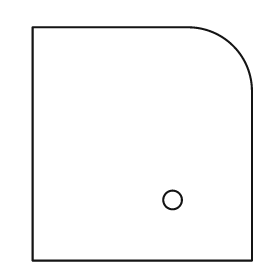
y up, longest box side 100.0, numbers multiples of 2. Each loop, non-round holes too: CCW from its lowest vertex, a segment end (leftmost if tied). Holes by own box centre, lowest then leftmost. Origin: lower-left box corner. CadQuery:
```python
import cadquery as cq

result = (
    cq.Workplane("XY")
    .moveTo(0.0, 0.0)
    .lineTo(94.0, 0.0)
    .lineTo(94.0, 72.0)
    .threePointArc((86.0, 92.0), (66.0, 100.0))
    .lineTo(0.0, 100.0)
    .close()
    .moveTo(60.0, 26.0)
    .circle(4.0)
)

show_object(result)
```